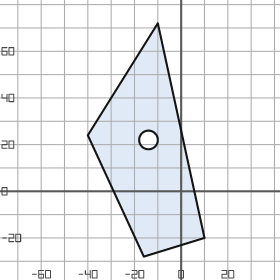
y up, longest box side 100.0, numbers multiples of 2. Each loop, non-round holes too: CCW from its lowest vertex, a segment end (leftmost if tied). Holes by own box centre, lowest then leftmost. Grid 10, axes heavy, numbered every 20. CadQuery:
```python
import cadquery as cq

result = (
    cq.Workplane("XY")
    .moveTo(-16.0, -28.0)
    .lineTo(10.0, -20.0)
    .lineTo(-10.0, 72.0)
    .lineTo(-40.0, 24.0)
    .close()
    .moveTo(-14.0, 22.0)
    .circle(4.0)
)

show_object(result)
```